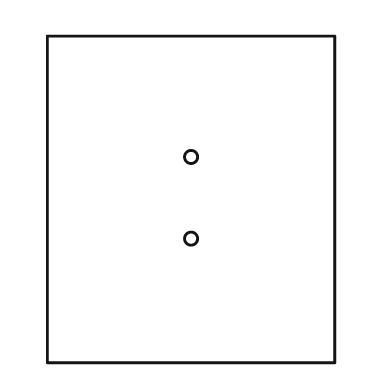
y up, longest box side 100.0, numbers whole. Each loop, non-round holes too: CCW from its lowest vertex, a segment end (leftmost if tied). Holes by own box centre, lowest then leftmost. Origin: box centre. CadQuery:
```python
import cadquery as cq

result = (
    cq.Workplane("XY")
    .moveTo(-44.0, -50.0)
    .lineTo(44.0, -50.0)
    .lineTo(44.0, 50.0)
    .lineTo(-44.0, 50.0)
    .close()
    .moveTo(0.0, -12.0)
    .circle(2.0)
    .moveTo(0.0, 13.0)
    .circle(2.0)
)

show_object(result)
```